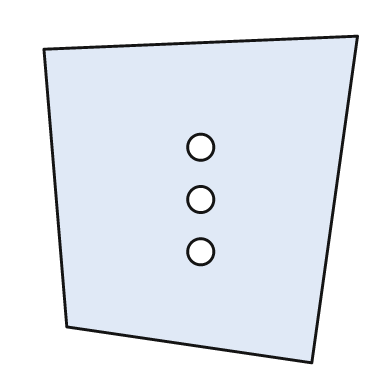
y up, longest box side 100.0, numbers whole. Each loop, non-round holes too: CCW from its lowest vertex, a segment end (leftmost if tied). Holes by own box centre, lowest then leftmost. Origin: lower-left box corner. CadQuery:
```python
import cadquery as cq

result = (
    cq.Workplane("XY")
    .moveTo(82.0, 0.0)
    .lineTo(96.0, 100.0)
    .lineTo(0.0, 96.0)
    .lineTo(7.0, 11.0)
    .close()
    .moveTo(48.0, 34.0)
    .circle(4.0)
    .moveTo(48.0, 50.0)
    .circle(4.0)
    .moveTo(48.0, 66.0)
    .circle(4.0)
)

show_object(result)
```